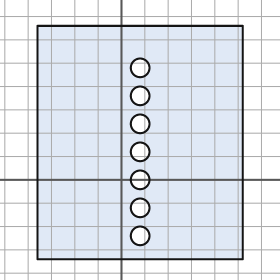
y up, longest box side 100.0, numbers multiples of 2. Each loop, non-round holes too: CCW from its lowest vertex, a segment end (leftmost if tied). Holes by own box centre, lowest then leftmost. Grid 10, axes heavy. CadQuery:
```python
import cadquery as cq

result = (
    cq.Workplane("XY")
    .moveTo(-36.0, -34.0)
    .lineTo(52.0, -34.0)
    .lineTo(52.0, 66.0)
    .lineTo(-36.0, 66.0)
    .close()
    .moveTo(8.0, -24.0)
    .circle(4.0)
    .moveTo(8.0, -12.0)
    .circle(4.0)
    .moveTo(8.0, 0.0)
    .circle(4.0)
    .moveTo(8.0, 12.0)
    .circle(4.0)
    .moveTo(8.0, 24.0)
    .circle(4.0)
    .moveTo(8.0, 36.0)
    .circle(4.0)
    .moveTo(8.0, 48.0)
    .circle(4.0)
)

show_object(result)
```